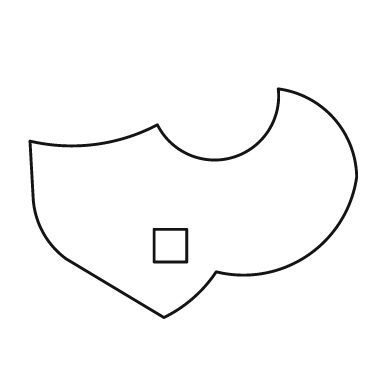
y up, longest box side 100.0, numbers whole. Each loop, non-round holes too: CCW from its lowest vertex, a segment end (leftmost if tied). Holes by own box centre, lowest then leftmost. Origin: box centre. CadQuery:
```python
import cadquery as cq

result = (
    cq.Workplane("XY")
    .moveTo(-9.0, -35.0)
    .threePointArc((0.0, -29.0), (7.0, -21.0))
    .threePointArc((35.0, -16.0), (50.0, 8.0))
    .threePointArc((43.0, 26.0), (26.0, 35.0))
    .threePointArc((12.0, 14.0), (-11.0, 24.0))
    .threePointArc((-30.0, 18.0), (-50.0, 19.0))
    .lineTo(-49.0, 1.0)
    .threePointArc((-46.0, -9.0), (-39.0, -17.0))
    .close()
    .moveTo(-12.0, -18.0)
    .lineTo(-2.0, -18.0)
    .lineTo(-2.0, -8.0)
    .lineTo(-12.0, -8.0)
    .close()
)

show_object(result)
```